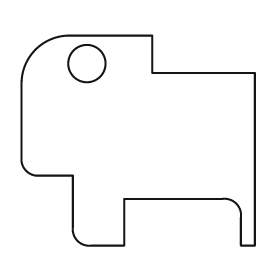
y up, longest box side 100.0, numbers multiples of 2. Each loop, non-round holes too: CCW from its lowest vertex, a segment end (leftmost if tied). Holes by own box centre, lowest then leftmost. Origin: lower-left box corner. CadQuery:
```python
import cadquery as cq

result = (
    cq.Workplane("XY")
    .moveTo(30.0, 0.0)
    .lineTo(44.0, 0.0)
    .lineTo(44.0, 20.0)
    .lineTo(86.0, 20.0)
    .threePointArc((92.0, 18.0), (94.0, 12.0))
    .lineTo(94.0, 0.0)
    .lineTo(100.0, 0.0)
    .lineTo(100.0, 74.0)
    .lineTo(56.0, 74.0)
    .lineTo(56.0, 90.0)
    .lineTo(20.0, 90.0)
    .threePointArc((6.0, 84.0), (0.0, 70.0))
    .lineTo(0.0, 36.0)
    .threePointArc((2.0, 32.0), (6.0, 30.0))
    .lineTo(22.0, 30.0)
    .lineTo(22.0, 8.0)
    .threePointArc((24.0, 2.0), (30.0, 0.0))
    .close()
    .moveTo(28.0, 78.0)
    .circle(8.0)
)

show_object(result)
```